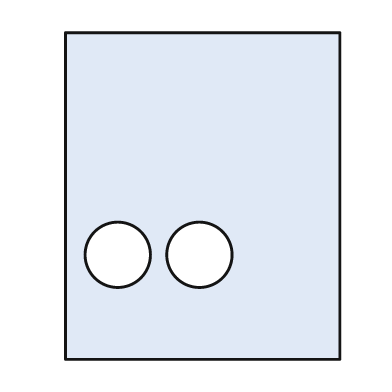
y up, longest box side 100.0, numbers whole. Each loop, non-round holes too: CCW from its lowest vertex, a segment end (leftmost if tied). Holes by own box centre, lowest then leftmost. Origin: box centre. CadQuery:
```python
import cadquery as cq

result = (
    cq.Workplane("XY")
    .moveTo(-42.0, -50.0)
    .lineTo(42.0, -50.0)
    .lineTo(42.0, 50.0)
    .lineTo(-42.0, 50.0)
    .close()
    .moveTo(-26.0, -18.0)
    .circle(10.0)
    .moveTo(-1.0, -18.0)
    .circle(10.0)
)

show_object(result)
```